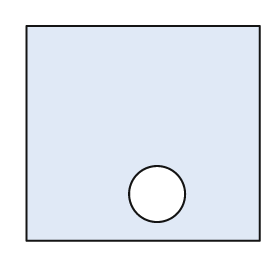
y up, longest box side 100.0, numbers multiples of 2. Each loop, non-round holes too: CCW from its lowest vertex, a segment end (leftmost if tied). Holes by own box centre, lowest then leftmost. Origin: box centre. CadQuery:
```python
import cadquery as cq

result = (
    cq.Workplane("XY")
    .moveTo(-50.0, -46.0)
    .lineTo(50.0, -46.0)
    .lineTo(50.0, 46.0)
    .lineTo(-50.0, 46.0)
    .close()
    .moveTo(6.0, -26.0)
    .circle(12.0)
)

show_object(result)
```